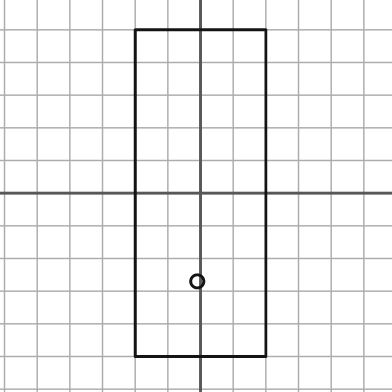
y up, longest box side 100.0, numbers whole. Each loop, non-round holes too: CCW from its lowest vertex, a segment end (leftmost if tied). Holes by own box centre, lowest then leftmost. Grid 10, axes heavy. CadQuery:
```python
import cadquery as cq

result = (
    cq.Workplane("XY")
    .moveTo(-20.0, -50.0)
    .lineTo(20.0, -50.0)
    .lineTo(20.0, 50.0)
    .lineTo(-20.0, 50.0)
    .close()
    .moveTo(-1.0, -27.0)
    .circle(2.0)
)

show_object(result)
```